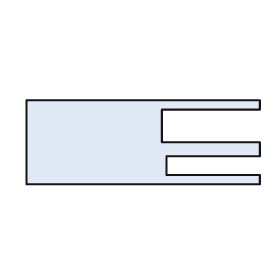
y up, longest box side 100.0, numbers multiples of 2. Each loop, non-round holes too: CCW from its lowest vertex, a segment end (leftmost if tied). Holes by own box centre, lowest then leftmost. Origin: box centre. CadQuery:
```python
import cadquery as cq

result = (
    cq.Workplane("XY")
    .moveTo(-50.0, -18.0)
    .lineTo(50.0, -18.0)
    .lineTo(50.0, -14.0)
    .lineTo(10.0, -14.0)
    .lineTo(10.0, -6.0)
    .lineTo(50.0, -6.0)
    .lineTo(50.0, 0.0)
    .lineTo(8.0, 0.0)
    .lineTo(8.0, 14.0)
    .lineTo(50.0, 14.0)
    .lineTo(50.0, 18.0)
    .lineTo(-50.0, 18.0)
    .close()
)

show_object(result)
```